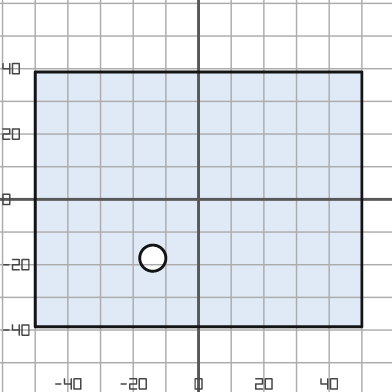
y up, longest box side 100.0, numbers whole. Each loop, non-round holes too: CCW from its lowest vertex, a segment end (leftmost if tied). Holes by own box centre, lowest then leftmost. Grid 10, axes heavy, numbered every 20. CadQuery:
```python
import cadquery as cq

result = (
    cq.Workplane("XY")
    .moveTo(-50.0, -39.0)
    .lineTo(50.0, -39.0)
    .lineTo(50.0, 39.0)
    .lineTo(-50.0, 39.0)
    .close()
    .moveTo(-14.0, -18.0)
    .circle(4.0)
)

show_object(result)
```